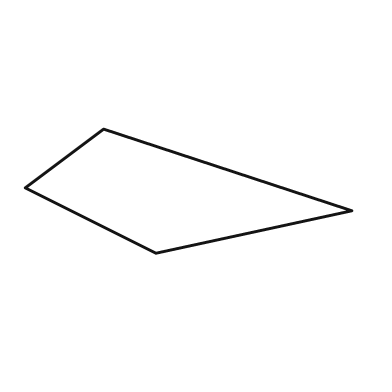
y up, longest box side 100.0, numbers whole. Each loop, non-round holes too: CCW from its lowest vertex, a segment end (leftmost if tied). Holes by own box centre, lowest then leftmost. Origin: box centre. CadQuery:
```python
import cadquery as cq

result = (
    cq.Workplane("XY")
    .moveTo(-10.0, -19.0)
    .lineTo(50.0, -6.0)
    .lineTo(-26.0, 19.0)
    .lineTo(-50.0, 1.0)
    .close()
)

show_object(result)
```